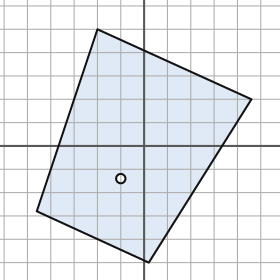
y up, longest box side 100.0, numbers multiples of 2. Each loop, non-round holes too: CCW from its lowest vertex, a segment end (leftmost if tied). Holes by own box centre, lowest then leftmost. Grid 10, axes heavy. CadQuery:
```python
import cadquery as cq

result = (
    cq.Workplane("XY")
    .moveTo(2.0, -50.0)
    .lineTo(46.0, 20.0)
    .lineTo(-20.0, 50.0)
    .lineTo(-46.0, -28.0)
    .close()
    .moveTo(-10.0, -14.0)
    .circle(2.0)
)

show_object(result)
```